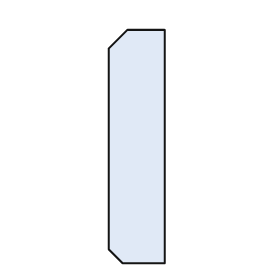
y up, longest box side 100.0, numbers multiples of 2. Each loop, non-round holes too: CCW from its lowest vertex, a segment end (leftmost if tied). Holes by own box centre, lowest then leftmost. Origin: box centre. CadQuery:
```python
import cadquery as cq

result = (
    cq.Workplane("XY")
    .moveTo(-6.0, -50.0)
    .lineTo(12.0, -50.0)
    .lineTo(12.0, 50.0)
    .lineTo(-4.0, 50.0)
    .lineTo(-12.0, 42.0)
    .lineTo(-12.0, -44.0)
    .close()
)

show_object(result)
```